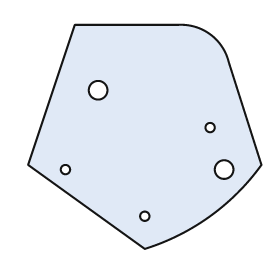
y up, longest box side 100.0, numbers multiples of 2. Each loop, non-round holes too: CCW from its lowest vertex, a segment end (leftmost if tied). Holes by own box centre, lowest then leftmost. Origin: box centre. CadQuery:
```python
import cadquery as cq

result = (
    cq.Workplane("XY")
    .moveTo(0.0, -48.0)
    .threePointArc((28.0, -34.0), (50.0, -12.0))
    .lineTo(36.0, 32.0)
    .threePointArc((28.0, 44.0), (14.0, 48.0))
    .lineTo(-30.0, 48.0)
    .lineTo(-50.0, -12.0)
    .close()
    .moveTo(0.0, -34.0)
    .circle(2.0)
    .moveTo(-34.0, -14.0)
    .circle(2.0)
    .moveTo(34.0, -14.0)
    .circle(4.0)
    .moveTo(28.0, 4.0)
    .circle(2.0)
    .moveTo(-20.0, 20.0)
    .circle(4.0)
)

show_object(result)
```